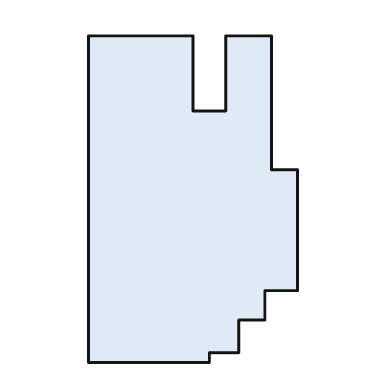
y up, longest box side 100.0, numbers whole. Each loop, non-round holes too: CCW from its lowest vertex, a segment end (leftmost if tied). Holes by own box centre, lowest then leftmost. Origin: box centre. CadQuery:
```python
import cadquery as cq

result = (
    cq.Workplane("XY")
    .moveTo(-32.0, -50.0)
    .lineTo(5.0, -50.0)
    .lineTo(5.0, -47.0)
    .lineTo(14.0, -47.0)
    .lineTo(14.0, -37.0)
    .lineTo(22.0, -37.0)
    .lineTo(22.0, -28.0)
    .lineTo(32.0, -28.0)
    .lineTo(32.0, 9.0)
    .lineTo(24.0, 9.0)
    .lineTo(24.0, 50.0)
    .lineTo(10.0, 50.0)
    .lineTo(10.0, 27.0)
    .lineTo(0.0, 27.0)
    .lineTo(0.0, 50.0)
    .lineTo(-32.0, 50.0)
    .close()
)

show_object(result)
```